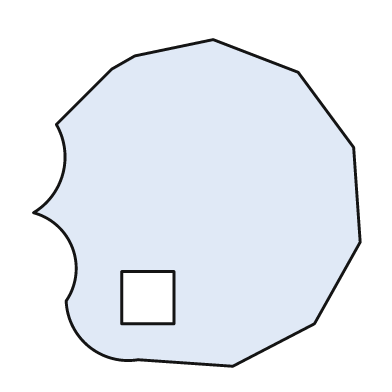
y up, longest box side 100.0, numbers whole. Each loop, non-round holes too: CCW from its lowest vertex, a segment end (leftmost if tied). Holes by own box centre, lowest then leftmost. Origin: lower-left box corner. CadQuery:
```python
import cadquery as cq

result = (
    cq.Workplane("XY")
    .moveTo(61.0, 0.0)
    .lineTo(86.0, 13.0)
    .lineTo(100.0, 38.0)
    .lineTo(98.0, 67.0)
    .lineTo(81.0, 90.0)
    .lineTo(55.0, 100.0)
    .lineTo(31.0, 95.0)
    .lineTo(24.0, 91.0)
    .lineTo(7.0, 74.0)
    .threePointArc((9.0, 59.0), (0.0, 47.0))
    .threePointArc((12.0, 36.0), (10.0, 20.0))
    .threePointArc((17.0, 6.0), (32.0, 2.0))
    .close()
    .moveTo(27.0, 13.0)
    .lineTo(43.0, 13.0)
    .lineTo(43.0, 29.0)
    .lineTo(27.0, 29.0)
    .close()
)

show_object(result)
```